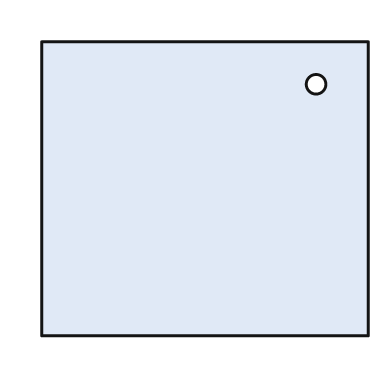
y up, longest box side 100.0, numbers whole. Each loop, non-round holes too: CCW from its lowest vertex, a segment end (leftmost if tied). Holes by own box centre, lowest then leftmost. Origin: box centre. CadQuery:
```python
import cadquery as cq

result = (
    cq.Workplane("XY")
    .moveTo(-50.0, -45.0)
    .lineTo(50.0, -45.0)
    .lineTo(50.0, 45.0)
    .lineTo(-50.0, 45.0)
    .close()
    .moveTo(34.0, 32.0)
    .circle(3.0)
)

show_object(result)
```